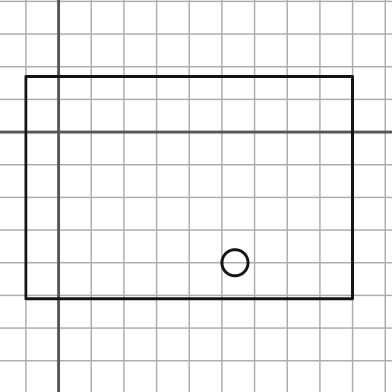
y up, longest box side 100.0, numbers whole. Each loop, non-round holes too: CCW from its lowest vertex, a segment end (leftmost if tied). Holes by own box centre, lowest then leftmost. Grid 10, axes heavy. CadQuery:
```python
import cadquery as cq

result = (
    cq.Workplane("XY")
    .moveTo(-10.0, -51.0)
    .lineTo(90.0, -51.0)
    .lineTo(90.0, 17.0)
    .lineTo(-10.0, 17.0)
    .close()
    .moveTo(54.0, -40.0)
    .circle(4.0)
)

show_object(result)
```